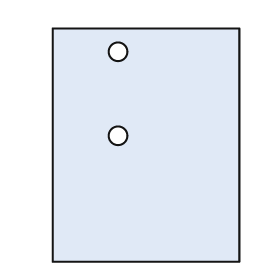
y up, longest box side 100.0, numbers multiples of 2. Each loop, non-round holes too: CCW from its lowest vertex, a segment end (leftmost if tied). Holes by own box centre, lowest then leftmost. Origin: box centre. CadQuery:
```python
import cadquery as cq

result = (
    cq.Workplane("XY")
    .moveTo(-40.0, -50.0)
    .lineTo(40.0, -50.0)
    .lineTo(40.0, 50.0)
    .lineTo(-40.0, 50.0)
    .close()
    .moveTo(-12.0, 4.0)
    .circle(4.0)
    .moveTo(-12.0, 40.0)
    .circle(4.0)
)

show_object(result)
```